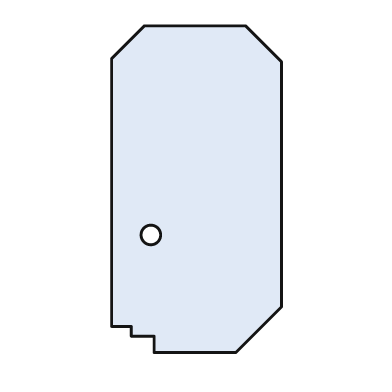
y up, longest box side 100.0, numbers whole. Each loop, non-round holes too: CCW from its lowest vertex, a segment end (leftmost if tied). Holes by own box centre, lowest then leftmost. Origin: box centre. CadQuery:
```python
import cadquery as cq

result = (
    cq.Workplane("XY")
    .moveTo(-13.0, -50.0)
    .lineTo(12.0, -50.0)
    .lineTo(26.0, -36.0)
    .lineTo(26.0, 39.0)
    .lineTo(15.0, 50.0)
    .lineTo(-16.0, 50.0)
    .lineTo(-26.0, 40.0)
    .lineTo(-26.0, -42.0)
    .lineTo(-20.0, -42.0)
    .lineTo(-20.0, -45.0)
    .lineTo(-13.0, -45.0)
    .close()
    .moveTo(-14.0, -14.0)
    .circle(3.0)
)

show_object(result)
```